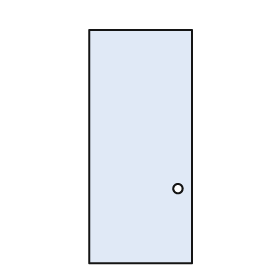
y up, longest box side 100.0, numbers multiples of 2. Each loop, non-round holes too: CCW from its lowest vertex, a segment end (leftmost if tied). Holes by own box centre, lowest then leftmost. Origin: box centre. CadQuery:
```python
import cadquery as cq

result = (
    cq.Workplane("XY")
    .moveTo(-22.0, -50.0)
    .lineTo(22.0, -50.0)
    .lineTo(22.0, 50.0)
    .lineTo(-22.0, 50.0)
    .close()
    .moveTo(16.0, -18.0)
    .circle(2.0)
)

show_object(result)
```